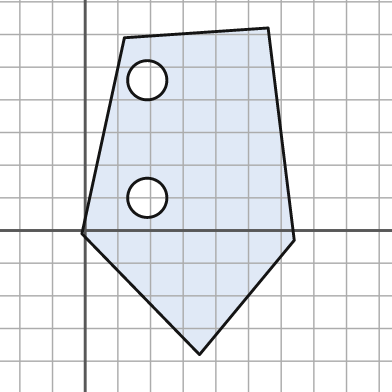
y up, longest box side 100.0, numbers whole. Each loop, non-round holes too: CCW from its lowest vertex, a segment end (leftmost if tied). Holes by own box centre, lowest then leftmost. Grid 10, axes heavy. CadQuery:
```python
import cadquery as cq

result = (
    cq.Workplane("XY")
    .moveTo(35.0, -38.0)
    .lineTo(64.0, -3.0)
    .lineTo(56.0, 62.0)
    .lineTo(12.0, 59.0)
    .lineTo(-1.0, -1.0)
    .close()
    .moveTo(19.0, 10.0)
    .circle(6.0)
    .moveTo(19.0, 46.0)
    .circle(6.0)
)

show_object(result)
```